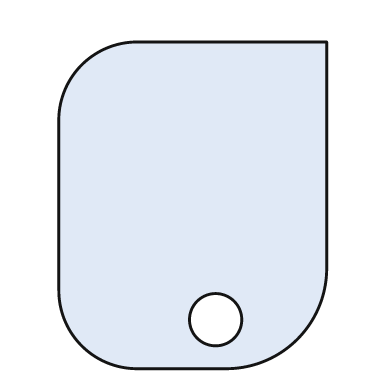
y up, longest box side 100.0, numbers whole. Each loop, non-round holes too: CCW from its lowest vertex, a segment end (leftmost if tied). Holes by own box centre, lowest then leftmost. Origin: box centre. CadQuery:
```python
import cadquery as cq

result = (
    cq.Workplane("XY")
    .moveTo(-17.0, -50.0)
    .lineTo(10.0, -50.0)
    .threePointArc((32.0, -41.0), (41.0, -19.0))
    .lineTo(41.0, 50.0)
    .lineTo(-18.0, 50.0)
    .threePointArc((-34.0, 43.0), (-41.0, 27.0))
    .lineTo(-41.0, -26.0)
    .threePointArc((-34.0, -43.0), (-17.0, -50.0))
    .close()
    .moveTo(7.0, -35.0)
    .circle(8.0)
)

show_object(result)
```